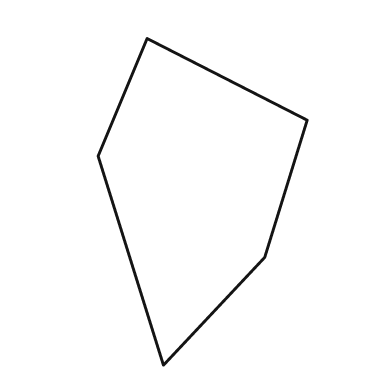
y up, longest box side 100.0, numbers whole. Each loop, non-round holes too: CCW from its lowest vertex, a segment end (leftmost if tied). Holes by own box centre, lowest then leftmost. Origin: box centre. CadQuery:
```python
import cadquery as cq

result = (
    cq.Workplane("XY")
    .moveTo(-12.0, -50.0)
    .lineTo(19.0, -17.0)
    .lineTo(32.0, 25.0)
    .lineTo(-17.0, 50.0)
    .lineTo(-32.0, 14.0)
    .close()
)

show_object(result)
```